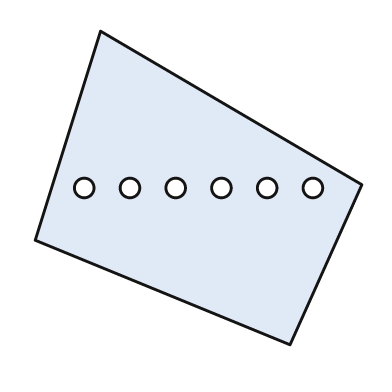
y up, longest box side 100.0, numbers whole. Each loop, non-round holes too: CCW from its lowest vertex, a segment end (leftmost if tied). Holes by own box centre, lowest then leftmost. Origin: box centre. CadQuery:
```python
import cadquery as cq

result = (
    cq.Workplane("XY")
    .moveTo(28.0, -48.0)
    .lineTo(50.0, 1.0)
    .lineTo(-30.0, 48.0)
    .lineTo(-50.0, -16.0)
    .close()
    .moveTo(-35.0, 0.0)
    .circle(3.0)
    .moveTo(-21.0, 0.0)
    .circle(3.0)
    .moveTo(-7.0, 0.0)
    .circle(3.0)
    .moveTo(7.0, 0.0)
    .circle(3.0)
    .moveTo(21.0, 0.0)
    .circle(3.0)
    .moveTo(35.0, 0.0)
    .circle(3.0)
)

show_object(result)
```